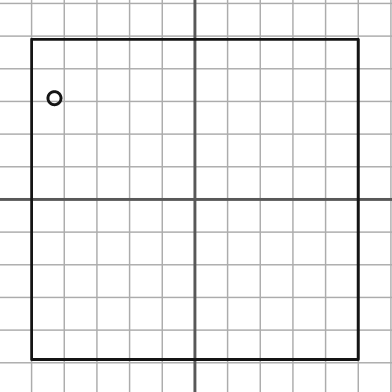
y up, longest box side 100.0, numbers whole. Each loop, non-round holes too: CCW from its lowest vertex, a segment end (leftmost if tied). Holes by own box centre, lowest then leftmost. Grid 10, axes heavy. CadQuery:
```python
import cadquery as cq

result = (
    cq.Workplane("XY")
    .moveTo(-50.0, -49.0)
    .lineTo(50.0, -49.0)
    .lineTo(50.0, 49.0)
    .lineTo(-50.0, 49.0)
    .close()
    .moveTo(-43.0, 31.0)
    .circle(2.0)
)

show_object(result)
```